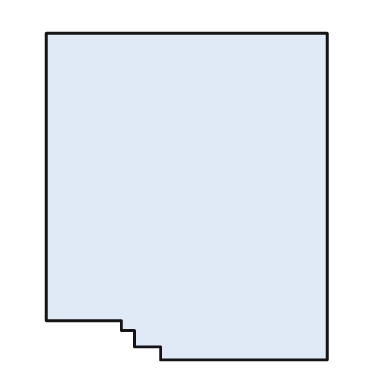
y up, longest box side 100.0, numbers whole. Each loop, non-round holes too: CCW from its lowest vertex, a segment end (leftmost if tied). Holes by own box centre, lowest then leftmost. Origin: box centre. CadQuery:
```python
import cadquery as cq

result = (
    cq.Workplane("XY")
    .moveTo(-8.0, -50.0)
    .lineTo(43.0, -50.0)
    .lineTo(43.0, 50.0)
    .lineTo(-43.0, 50.0)
    .lineTo(-43.0, -38.0)
    .lineTo(-20.0, -38.0)
    .lineTo(-20.0, -41.0)
    .lineTo(-16.0, -41.0)
    .lineTo(-16.0, -46.0)
    .lineTo(-8.0, -46.0)
    .close()
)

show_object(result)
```